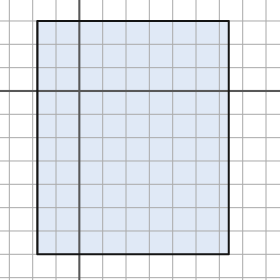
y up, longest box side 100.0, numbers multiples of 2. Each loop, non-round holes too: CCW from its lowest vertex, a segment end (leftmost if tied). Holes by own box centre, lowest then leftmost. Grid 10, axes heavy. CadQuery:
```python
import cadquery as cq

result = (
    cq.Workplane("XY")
    .moveTo(-18.0, -70.0)
    .lineTo(64.0, -70.0)
    .lineTo(64.0, 30.0)
    .lineTo(-18.0, 30.0)
    .close()
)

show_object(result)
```